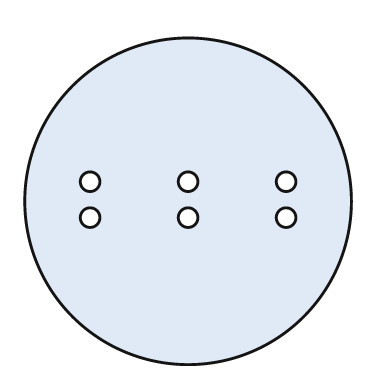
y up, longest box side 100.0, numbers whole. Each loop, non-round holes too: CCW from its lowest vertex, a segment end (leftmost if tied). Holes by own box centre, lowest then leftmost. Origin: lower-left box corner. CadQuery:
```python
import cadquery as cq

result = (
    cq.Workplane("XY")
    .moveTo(50.0, 50.0)
    .circle(50.0)
    .moveTo(20.0, 45.0)
    .circle(3.0)
    .moveTo(50.0, 45.0)
    .circle(3.0)
    .moveTo(80.0, 45.0)
    .circle(3.0)
    .moveTo(20.0, 56.0)
    .circle(3.0)
    .moveTo(50.0, 56.0)
    .circle(3.0)
    .moveTo(80.0, 56.0)
    .circle(3.0)
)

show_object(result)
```